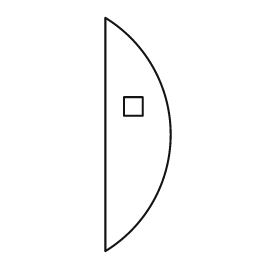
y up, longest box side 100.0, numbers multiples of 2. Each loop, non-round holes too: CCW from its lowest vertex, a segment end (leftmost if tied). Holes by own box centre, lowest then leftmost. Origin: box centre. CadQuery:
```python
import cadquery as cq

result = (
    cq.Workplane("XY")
    .moveTo(-14.0, -50.0)
    .threePointArc((14.0, 0.0), (-14.0, 50.0))
    .close()
    .moveTo(-6.0, 8.0)
    .lineTo(2.0, 8.0)
    .lineTo(2.0, 16.0)
    .lineTo(-6.0, 16.0)
    .close()
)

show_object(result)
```